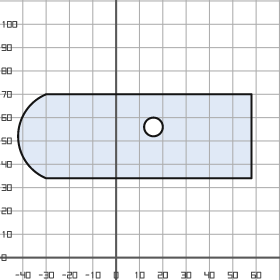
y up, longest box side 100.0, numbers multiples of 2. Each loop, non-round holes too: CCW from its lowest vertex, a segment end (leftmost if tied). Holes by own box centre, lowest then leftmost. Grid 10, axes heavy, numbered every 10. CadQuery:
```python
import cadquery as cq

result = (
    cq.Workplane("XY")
    .moveTo(-30.0, 34.0)
    .lineTo(58.0, 34.0)
    .lineTo(58.0, 70.0)
    .lineTo(-30.0, 70.0)
    .threePointArc((-42.0, 52.0), (-30.0, 34.0))
    .close()
    .moveTo(16.0, 56.0)
    .circle(4.0)
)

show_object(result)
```